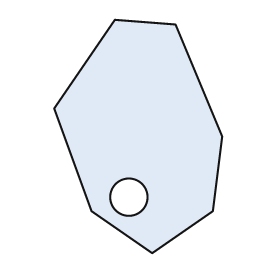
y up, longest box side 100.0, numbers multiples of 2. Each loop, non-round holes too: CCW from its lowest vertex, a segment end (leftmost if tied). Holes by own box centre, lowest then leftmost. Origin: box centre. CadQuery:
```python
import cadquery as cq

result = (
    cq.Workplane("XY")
    .moveTo(6.0, -50.0)
    .lineTo(32.0, -32.0)
    .lineTo(36.0, 0.0)
    .lineTo(16.0, 48.0)
    .lineTo(-10.0, 50.0)
    .lineTo(-36.0, 12.0)
    .lineTo(-20.0, -32.0)
    .close()
    .moveTo(-4.0, -26.0)
    .circle(8.0)
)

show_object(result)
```